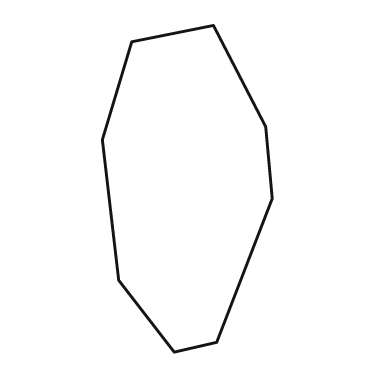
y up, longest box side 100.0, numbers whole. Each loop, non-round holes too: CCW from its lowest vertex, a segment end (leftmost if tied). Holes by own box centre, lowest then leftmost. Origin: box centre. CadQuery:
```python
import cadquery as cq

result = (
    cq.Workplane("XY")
    .moveTo(-4.0, -50.0)
    .lineTo(9.0, -47.0)
    .lineTo(26.0, -3.0)
    .lineTo(24.0, 19.0)
    .lineTo(8.0, 50.0)
    .lineTo(-17.0, 45.0)
    .lineTo(-26.0, 15.0)
    .lineTo(-21.0, -28.0)
    .close()
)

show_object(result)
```